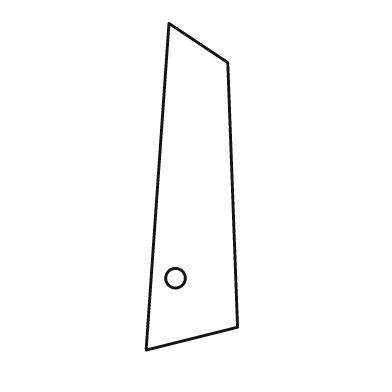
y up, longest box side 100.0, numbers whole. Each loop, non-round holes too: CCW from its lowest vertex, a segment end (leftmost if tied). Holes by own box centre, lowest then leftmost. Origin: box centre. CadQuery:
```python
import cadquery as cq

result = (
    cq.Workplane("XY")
    .moveTo(-14.0, -50.0)
    .lineTo(14.0, -43.0)
    .lineTo(11.0, 38.0)
    .lineTo(-7.0, 50.0)
    .close()
    .moveTo(-5.0, -28.0)
    .circle(3.0)
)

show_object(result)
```